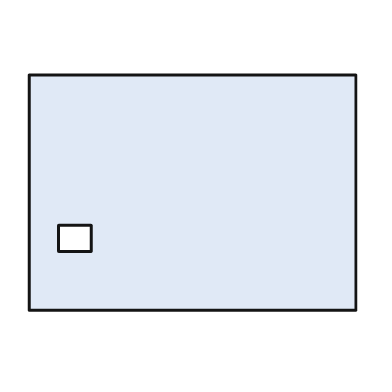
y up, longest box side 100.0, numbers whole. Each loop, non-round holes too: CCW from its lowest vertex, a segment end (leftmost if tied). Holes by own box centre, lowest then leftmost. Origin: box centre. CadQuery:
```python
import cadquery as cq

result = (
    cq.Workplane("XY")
    .moveTo(-50.0, -36.0)
    .lineTo(50.0, -36.0)
    .lineTo(50.0, 36.0)
    .lineTo(-50.0, 36.0)
    .close()
    .moveTo(-41.0, -18.0)
    .lineTo(-31.0, -18.0)
    .lineTo(-31.0, -10.0)
    .lineTo(-41.0, -10.0)
    .close()
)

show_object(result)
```